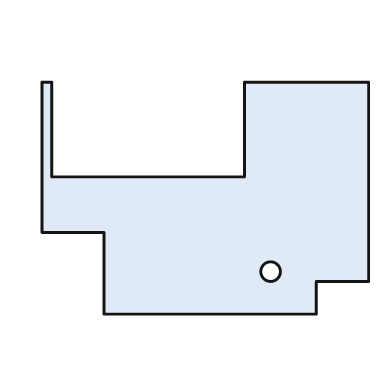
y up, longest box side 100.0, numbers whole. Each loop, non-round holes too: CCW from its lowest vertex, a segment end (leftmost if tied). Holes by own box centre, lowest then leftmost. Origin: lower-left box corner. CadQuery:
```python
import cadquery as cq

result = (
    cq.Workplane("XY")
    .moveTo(19.0, 0.0)
    .lineTo(84.0, 0.0)
    .lineTo(84.0, 10.0)
    .lineTo(100.0, 10.0)
    .lineTo(100.0, 71.0)
    .lineTo(62.0, 71.0)
    .lineTo(62.0, 42.0)
    .lineTo(3.0, 42.0)
    .lineTo(3.0, 71.0)
    .lineTo(0.0, 71.0)
    .lineTo(0.0, 25.0)
    .lineTo(19.0, 25.0)
    .close()
    .moveTo(70.0, 13.0)
    .circle(3.0)
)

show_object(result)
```